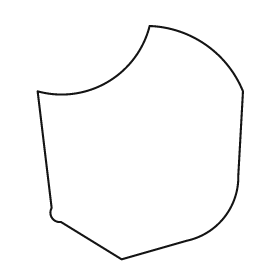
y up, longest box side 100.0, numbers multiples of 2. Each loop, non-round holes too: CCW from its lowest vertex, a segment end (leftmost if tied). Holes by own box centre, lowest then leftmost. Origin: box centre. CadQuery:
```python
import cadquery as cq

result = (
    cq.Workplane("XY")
    .moveTo(-8.0, -50.0)
    .lineTo(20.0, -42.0)
    .threePointArc((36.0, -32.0), (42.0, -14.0))
    .lineTo(44.0, 22.0)
    .threePointArc((28.0, 42.0), (4.0, 50.0))
    .threePointArc((-14.0, 26.0), (-44.0, 22.0))
    .lineTo(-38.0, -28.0)
    .threePointArc((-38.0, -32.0), (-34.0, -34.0))
    .close()
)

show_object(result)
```